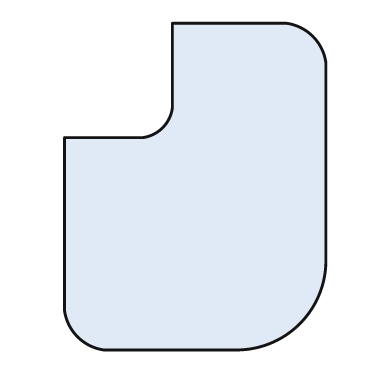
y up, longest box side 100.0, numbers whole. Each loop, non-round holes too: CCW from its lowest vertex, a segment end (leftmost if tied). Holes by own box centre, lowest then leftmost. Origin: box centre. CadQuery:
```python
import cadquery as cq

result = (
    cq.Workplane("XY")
    .moveTo(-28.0, -50.0)
    .lineTo(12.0, -50.0)
    .threePointArc((32.0, -42.0), (40.0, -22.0))
    .lineTo(40.0, 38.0)
    .threePointArc((36.0, 46.0), (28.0, 50.0))
    .lineTo(-7.0, 50.0)
    .lineTo(-7.0, 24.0)
    .threePointArc((-10.0, 18.0), (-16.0, 15.0))
    .lineTo(-40.0, 15.0)
    .lineTo(-40.0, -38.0)
    .threePointArc((-36.0, -46.0), (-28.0, -50.0))
    .close()
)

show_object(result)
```